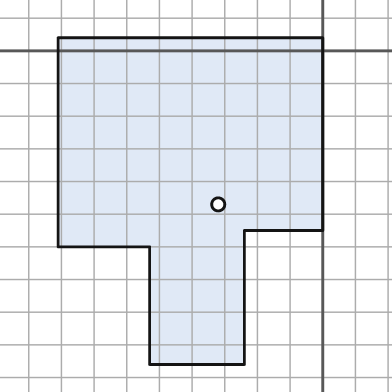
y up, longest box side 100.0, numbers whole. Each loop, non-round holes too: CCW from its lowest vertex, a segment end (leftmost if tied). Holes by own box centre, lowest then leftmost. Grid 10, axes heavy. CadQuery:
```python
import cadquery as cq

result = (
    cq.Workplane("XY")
    .moveTo(-53.0, -96.0)
    .lineTo(-24.0, -96.0)
    .lineTo(-24.0, -55.0)
    .lineTo(0.0, -55.0)
    .lineTo(0.0, 4.0)
    .lineTo(-81.0, 4.0)
    .lineTo(-81.0, -60.0)
    .lineTo(-53.0, -60.0)
    .close()
    .moveTo(-32.0, -47.0)
    .circle(2.0)
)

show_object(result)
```